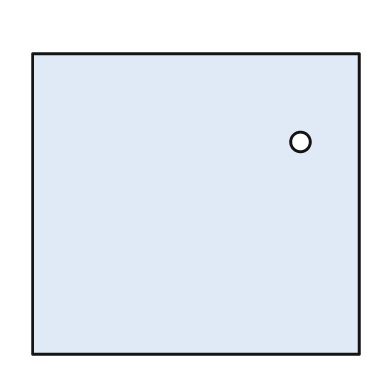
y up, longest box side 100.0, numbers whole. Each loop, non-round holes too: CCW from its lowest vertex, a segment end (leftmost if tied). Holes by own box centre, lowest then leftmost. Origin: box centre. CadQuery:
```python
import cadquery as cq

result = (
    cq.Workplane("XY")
    .moveTo(-50.0, -46.0)
    .lineTo(50.0, -46.0)
    .lineTo(50.0, 46.0)
    .lineTo(-50.0, 46.0)
    .close()
    .moveTo(32.0, 19.0)
    .circle(3.0)
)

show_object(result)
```